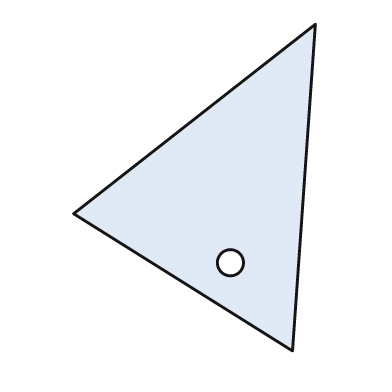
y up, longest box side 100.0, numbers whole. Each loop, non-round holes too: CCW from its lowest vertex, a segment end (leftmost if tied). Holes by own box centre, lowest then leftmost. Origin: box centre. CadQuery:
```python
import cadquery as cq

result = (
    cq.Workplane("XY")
    .moveTo(30.0, -50.0)
    .lineTo(37.0, 50.0)
    .lineTo(-37.0, -8.0)
    .close()
    .moveTo(11.0, -23.0)
    .circle(4.0)
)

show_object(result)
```